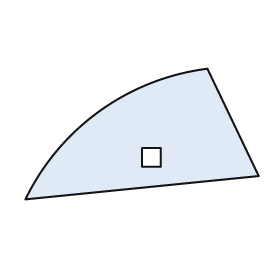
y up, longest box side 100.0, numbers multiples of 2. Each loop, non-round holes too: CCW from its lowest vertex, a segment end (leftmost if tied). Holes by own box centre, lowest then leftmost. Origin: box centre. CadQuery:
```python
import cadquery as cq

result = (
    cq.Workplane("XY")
    .moveTo(-50.0, -28.0)
    .lineTo(50.0, -18.0)
    .lineTo(28.0, 28.0)
    .threePointArc((-18.0, 10.0), (-50.0, -28.0))
    .close()
    .moveTo(0.0, -14.0)
    .lineTo(8.0, -14.0)
    .lineTo(8.0, -6.0)
    .lineTo(0.0, -6.0)
    .close()
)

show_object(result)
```